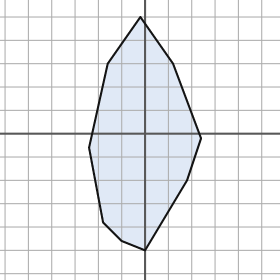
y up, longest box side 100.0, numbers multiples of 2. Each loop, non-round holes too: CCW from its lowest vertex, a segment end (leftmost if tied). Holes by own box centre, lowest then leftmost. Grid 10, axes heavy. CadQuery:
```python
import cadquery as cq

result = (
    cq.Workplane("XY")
    .moveTo(0.0, -50.0)
    .lineTo(18.0, -20.0)
    .lineTo(24.0, -2.0)
    .lineTo(12.0, 30.0)
    .lineTo(-2.0, 50.0)
    .lineTo(-16.0, 30.0)
    .lineTo(-24.0, -6.0)
    .lineTo(-18.0, -38.0)
    .lineTo(-10.0, -46.0)
    .close()
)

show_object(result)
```